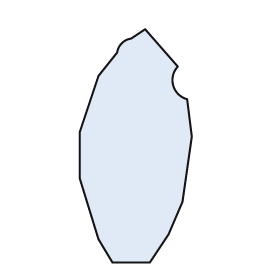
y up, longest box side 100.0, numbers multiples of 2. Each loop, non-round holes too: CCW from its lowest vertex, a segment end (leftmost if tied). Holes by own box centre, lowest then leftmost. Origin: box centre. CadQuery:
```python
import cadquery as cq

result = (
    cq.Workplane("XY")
    .moveTo(-10.0, -50.0)
    .lineTo(6.0, -50.0)
    .lineTo(14.0, -38.0)
    .lineTo(20.0, -24.0)
    .lineTo(24.0, 4.0)
    .lineTo(22.0, 20.0)
    .threePointArc((16.0, 26.0), (18.0, 34.0))
    .lineTo(4.0, 50.0)
    .lineTo(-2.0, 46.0)
    .threePointArc((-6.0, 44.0), (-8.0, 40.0))
    .lineTo(-16.0, 30.0)
    .lineTo(-24.0, 6.0)
    .lineTo(-24.0, -14.0)
    .lineTo(-16.0, -40.0)
    .close()
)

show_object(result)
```